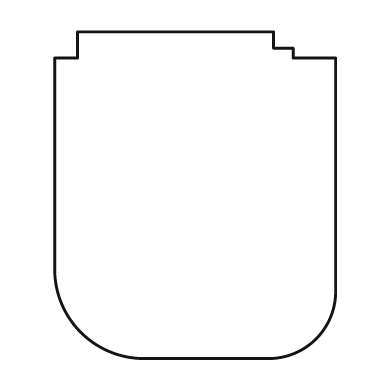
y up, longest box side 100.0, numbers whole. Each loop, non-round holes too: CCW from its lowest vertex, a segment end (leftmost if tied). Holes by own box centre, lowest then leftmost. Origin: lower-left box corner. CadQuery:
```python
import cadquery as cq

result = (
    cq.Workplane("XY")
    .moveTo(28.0, 0.0)
    .lineTo(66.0, 0.0)
    .threePointArc((80.0, 6.0), (86.0, 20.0))
    .lineTo(86.0, 92.0)
    .lineTo(73.0, 92.0)
    .lineTo(73.0, 95.0)
    .lineTo(67.0, 95.0)
    .lineTo(67.0, 100.0)
    .lineTo(7.0, 100.0)
    .lineTo(7.0, 92.0)
    .lineTo(0.0, 92.0)
    .lineTo(0.0, 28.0)
    .threePointArc((8.0, 8.0), (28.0, 0.0))
    .close()
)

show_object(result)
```